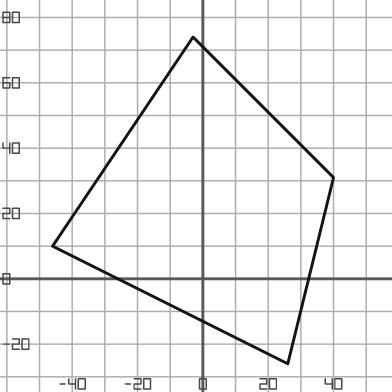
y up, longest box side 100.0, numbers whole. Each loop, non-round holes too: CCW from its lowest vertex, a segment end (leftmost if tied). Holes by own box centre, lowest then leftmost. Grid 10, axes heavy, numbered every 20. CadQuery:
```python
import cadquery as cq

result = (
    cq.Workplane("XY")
    .moveTo(26.0, -26.0)
    .lineTo(40.0, 31.0)
    .lineTo(-3.0, 74.0)
    .lineTo(-46.0, 10.0)
    .close()
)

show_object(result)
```